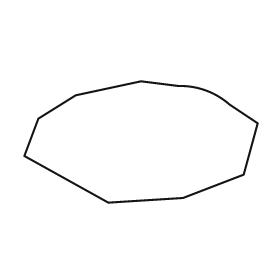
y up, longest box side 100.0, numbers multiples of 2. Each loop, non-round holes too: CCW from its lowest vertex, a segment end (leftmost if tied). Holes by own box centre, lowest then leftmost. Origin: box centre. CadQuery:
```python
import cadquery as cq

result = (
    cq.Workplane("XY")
    .moveTo(-14.0, -26.0)
    .lineTo(18.0, -24.0)
    .lineTo(44.0, -14.0)
    .lineTo(50.0, 8.0)
    .lineTo(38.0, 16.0)
    .threePointArc((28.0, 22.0), (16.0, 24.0))
    .lineTo(0.0, 26.0)
    .lineTo(-28.0, 20.0)
    .lineTo(-44.0, 10.0)
    .lineTo(-50.0, -6.0)
    .close()
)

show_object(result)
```